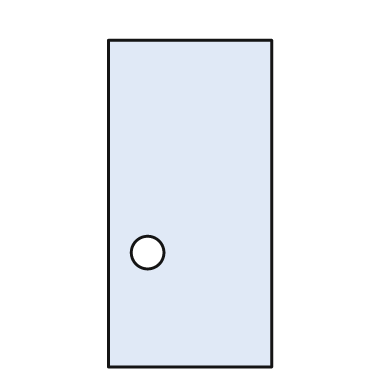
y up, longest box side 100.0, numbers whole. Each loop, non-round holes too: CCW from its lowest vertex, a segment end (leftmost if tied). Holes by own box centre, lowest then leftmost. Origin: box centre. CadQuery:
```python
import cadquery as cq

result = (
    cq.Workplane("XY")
    .moveTo(-25.0, -50.0)
    .lineTo(25.0, -50.0)
    .lineTo(25.0, 50.0)
    .lineTo(-25.0, 50.0)
    .close()
    .moveTo(-13.0, -15.0)
    .circle(5.0)
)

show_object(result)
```